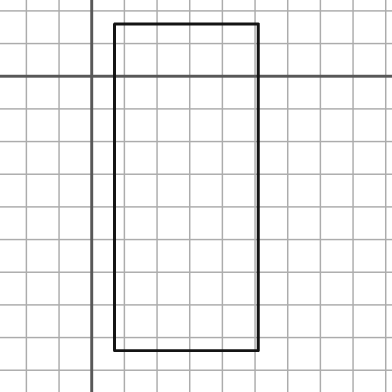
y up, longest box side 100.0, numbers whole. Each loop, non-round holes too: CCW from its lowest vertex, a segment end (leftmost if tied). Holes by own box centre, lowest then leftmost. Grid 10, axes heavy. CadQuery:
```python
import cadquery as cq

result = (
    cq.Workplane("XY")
    .moveTo(7.0, -84.0)
    .lineTo(51.0, -84.0)
    .lineTo(51.0, 16.0)
    .lineTo(7.0, 16.0)
    .close()
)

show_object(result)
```